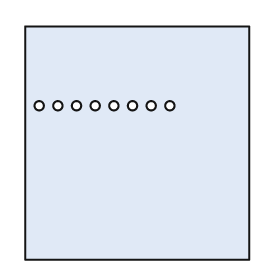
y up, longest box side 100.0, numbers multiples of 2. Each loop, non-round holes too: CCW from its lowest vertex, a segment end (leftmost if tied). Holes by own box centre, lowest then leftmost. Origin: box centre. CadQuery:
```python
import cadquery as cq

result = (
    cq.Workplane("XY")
    .moveTo(-48.0, -50.0)
    .lineTo(48.0, -50.0)
    .lineTo(48.0, 50.0)
    .lineTo(-48.0, 50.0)
    .close()
    .moveTo(-42.0, 16.0)
    .circle(2.0)
    .moveTo(-34.0, 16.0)
    .circle(2.0)
    .moveTo(-26.0, 16.0)
    .circle(2.0)
    .moveTo(-18.0, 16.0)
    .circle(2.0)
    .moveTo(-10.0, 16.0)
    .circle(2.0)
    .moveTo(-2.0, 16.0)
    .circle(2.0)
    .moveTo(6.0, 16.0)
    .circle(2.0)
    .moveTo(14.0, 16.0)
    .circle(2.0)
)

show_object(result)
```